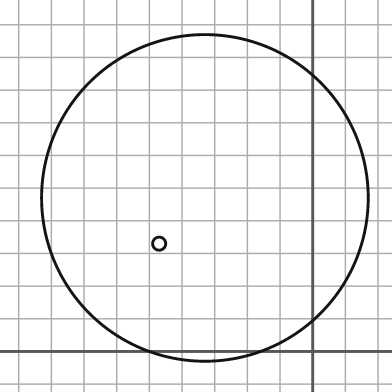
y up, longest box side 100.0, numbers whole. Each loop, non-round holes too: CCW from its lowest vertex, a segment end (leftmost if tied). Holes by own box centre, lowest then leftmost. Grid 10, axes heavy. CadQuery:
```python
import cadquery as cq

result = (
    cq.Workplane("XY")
    .moveTo(-33.0, 47.0)
    .circle(50.0)
    .moveTo(-47.0, 33.0)
    .circle(2.0)
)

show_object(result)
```